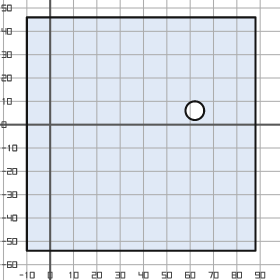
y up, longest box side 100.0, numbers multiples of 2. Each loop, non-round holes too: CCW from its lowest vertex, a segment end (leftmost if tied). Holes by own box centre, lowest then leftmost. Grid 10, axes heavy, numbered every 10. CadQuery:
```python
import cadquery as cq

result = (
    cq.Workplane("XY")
    .moveTo(-10.0, -54.0)
    .lineTo(88.0, -54.0)
    .lineTo(88.0, 46.0)
    .lineTo(-10.0, 46.0)
    .close()
    .moveTo(62.0, 6.0)
    .circle(4.0)
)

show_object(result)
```